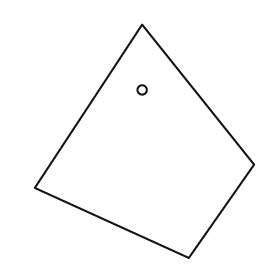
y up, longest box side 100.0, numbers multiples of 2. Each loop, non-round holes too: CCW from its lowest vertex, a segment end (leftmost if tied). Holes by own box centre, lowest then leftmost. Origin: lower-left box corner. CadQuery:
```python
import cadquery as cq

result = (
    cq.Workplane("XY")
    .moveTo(66.0, 0.0)
    .lineTo(94.0, 40.0)
    .lineTo(46.0, 100.0)
    .lineTo(0.0, 30.0)
    .close()
    .moveTo(46.0, 72.0)
    .circle(2.0)
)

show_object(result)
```